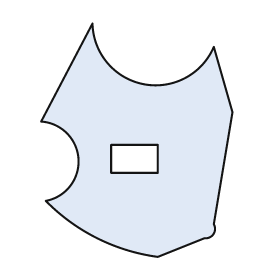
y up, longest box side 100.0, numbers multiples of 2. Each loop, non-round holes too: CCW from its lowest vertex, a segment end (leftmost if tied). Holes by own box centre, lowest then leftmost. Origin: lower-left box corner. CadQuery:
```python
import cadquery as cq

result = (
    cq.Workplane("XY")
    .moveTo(50.0, 0.0)
    .lineTo(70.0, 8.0)
    .threePointArc((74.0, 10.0), (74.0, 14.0))
    .lineTo(82.0, 62.0)
    .lineTo(74.0, 90.0)
    .threePointArc((44.0, 74.0), (22.0, 100.0))
    .lineTo(0.0, 58.0)
    .threePointArc((16.0, 42.0), (2.0, 24.0))
    .threePointArc((24.0, 8.0), (50.0, 0.0))
    .close()
    .moveTo(30.0, 36.0)
    .lineTo(50.0, 36.0)
    .lineTo(50.0, 48.0)
    .lineTo(30.0, 48.0)
    .close()
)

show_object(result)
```